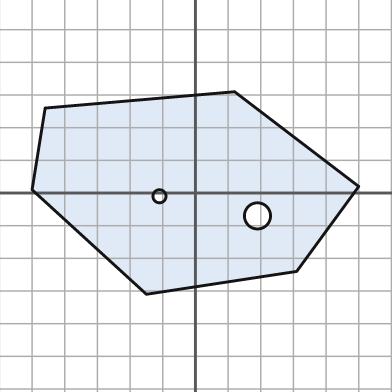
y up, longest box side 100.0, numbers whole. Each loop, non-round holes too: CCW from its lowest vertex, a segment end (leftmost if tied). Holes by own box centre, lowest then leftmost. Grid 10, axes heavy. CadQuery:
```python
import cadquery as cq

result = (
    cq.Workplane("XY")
    .moveTo(-15.0, -31.0)
    .lineTo(31.0, -24.0)
    .lineTo(50.0, 2.0)
    .lineTo(12.0, 31.0)
    .lineTo(-46.0, 26.0)
    .lineTo(-50.0, 1.0)
    .close()
    .moveTo(19.0, -7.0)
    .circle(4.0)
    .moveTo(-11.0, -1.0)
    .circle(2.0)
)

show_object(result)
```